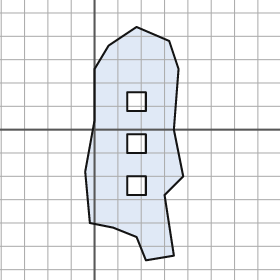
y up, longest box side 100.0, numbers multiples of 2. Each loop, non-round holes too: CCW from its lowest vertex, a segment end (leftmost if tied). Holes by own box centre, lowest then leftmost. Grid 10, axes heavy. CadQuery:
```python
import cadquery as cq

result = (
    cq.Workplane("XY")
    .moveTo(22.0, -56.0)
    .lineTo(34.0, -54.0)
    .lineTo(30.0, -28.0)
    .lineTo(38.0, -20.0)
    .lineTo(34.0, 0.0)
    .lineTo(36.0, 26.0)
    .lineTo(32.0, 38.0)
    .lineTo(18.0, 44.0)
    .lineTo(6.0, 36.0)
    .lineTo(0.0, 26.0)
    .lineTo(0.0, 4.0)
    .lineTo(-4.0, -18.0)
    .lineTo(-2.0, -40.0)
    .lineTo(8.0, -42.0)
    .lineTo(18.0, -46.0)
    .close()
    .moveTo(14.0, -28.0)
    .lineTo(22.0, -28.0)
    .lineTo(22.0, -20.0)
    .lineTo(14.0, -20.0)
    .close()
    .moveTo(14.0, -10.0)
    .lineTo(22.0, -10.0)
    .lineTo(22.0, -2.0)
    .lineTo(14.0, -2.0)
    .close()
    .moveTo(14.0, 8.0)
    .lineTo(22.0, 8.0)
    .lineTo(22.0, 16.0)
    .lineTo(14.0, 16.0)
    .close()
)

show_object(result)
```